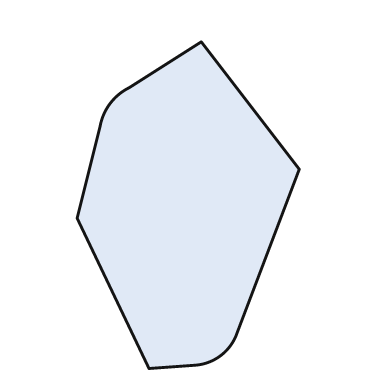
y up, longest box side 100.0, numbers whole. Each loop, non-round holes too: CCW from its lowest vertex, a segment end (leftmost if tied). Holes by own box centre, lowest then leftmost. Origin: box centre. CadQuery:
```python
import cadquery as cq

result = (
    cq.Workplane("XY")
    .moveTo(-12.0, -50.0)
    .lineTo(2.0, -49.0)
    .threePointArc((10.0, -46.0), (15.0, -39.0))
    .lineTo(34.0, 11.0)
    .lineTo(4.0, 50.0)
    .lineTo(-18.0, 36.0)
    .threePointArc((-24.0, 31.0), (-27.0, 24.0))
    .lineTo(-34.0, -4.0)
    .close()
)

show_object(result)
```